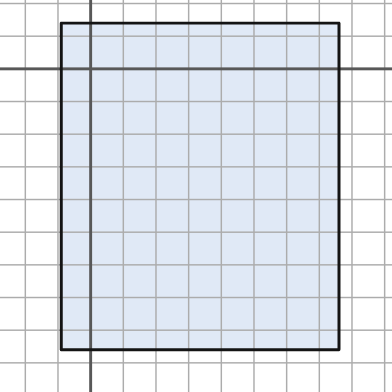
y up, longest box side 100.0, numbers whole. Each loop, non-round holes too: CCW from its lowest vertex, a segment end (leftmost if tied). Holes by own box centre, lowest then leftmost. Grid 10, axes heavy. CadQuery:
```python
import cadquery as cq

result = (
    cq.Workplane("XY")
    .moveTo(-9.0, -86.0)
    .lineTo(76.0, -86.0)
    .lineTo(76.0, 14.0)
    .lineTo(-9.0, 14.0)
    .close()
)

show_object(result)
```